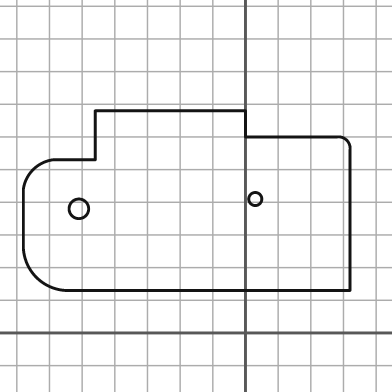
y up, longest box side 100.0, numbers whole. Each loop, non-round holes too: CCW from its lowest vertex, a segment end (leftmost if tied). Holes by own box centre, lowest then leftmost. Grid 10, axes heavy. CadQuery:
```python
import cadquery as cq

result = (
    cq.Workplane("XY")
    .moveTo(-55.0, 13.0)
    .lineTo(32.0, 13.0)
    .lineTo(32.0, 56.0)
    .threePointArc((31.0, 59.0), (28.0, 60.0))
    .lineTo(0.0, 60.0)
    .lineTo(0.0, 68.0)
    .lineTo(-46.0, 68.0)
    .lineTo(-46.0, 53.0)
    .lineTo(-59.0, 53.0)
    .threePointArc((-65.0, 50.0), (-68.0, 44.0))
    .lineTo(-68.0, 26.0)
    .threePointArc((-64.0, 17.0), (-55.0, 13.0))
    .close()
    .moveTo(-51.0, 38.0)
    .circle(3.0)
    .moveTo(3.0, 41.0)
    .circle(2.0)
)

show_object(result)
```